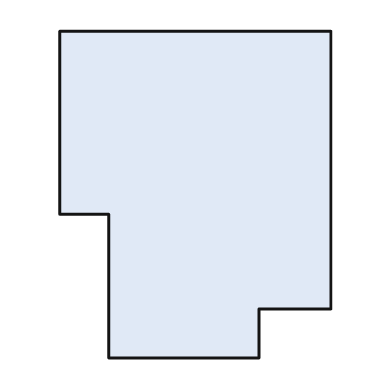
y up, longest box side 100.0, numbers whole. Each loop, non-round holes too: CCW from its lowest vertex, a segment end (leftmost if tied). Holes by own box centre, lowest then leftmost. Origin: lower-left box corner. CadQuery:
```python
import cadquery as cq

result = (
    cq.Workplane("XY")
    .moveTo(15.0, 0.0)
    .lineTo(61.0, 0.0)
    .lineTo(61.0, 15.0)
    .lineTo(83.0, 15.0)
    .lineTo(83.0, 100.0)
    .lineTo(0.0, 100.0)
    .lineTo(0.0, 44.0)
    .lineTo(15.0, 44.0)
    .close()
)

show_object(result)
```